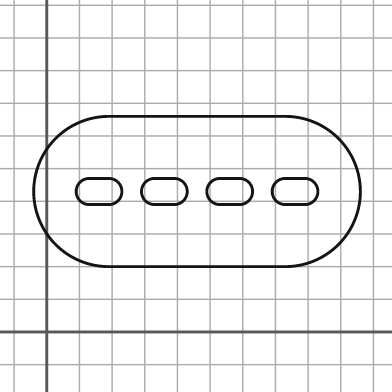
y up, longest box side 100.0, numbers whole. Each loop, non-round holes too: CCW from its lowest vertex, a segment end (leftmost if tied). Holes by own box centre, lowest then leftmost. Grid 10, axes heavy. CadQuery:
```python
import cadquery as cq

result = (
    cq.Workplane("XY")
    .moveTo(19.0, 20.0)
    .lineTo(73.0, 20.0)
    .threePointArc((96.0, 43.0), (73.0, 66.0))
    .lineTo(19.0, 66.0)
    .threePointArc((-4.0, 43.0), (19.0, 20.0))
    .close()
    .moveTo(13.0, 39.0)
    .lineTo(19.0, 39.0)
    .threePointArc((23.0, 43.0), (19.0, 47.0))
    .lineTo(13.0, 47.0)
    .threePointArc((9.0, 43.0), (13.0, 39.0))
    .close()
    .moveTo(33.0, 39.0)
    .lineTo(39.0, 39.0)
    .threePointArc((43.0, 43.0), (39.0, 47.0))
    .lineTo(33.0, 47.0)
    .threePointArc((29.0, 43.0), (33.0, 39.0))
    .close()
    .moveTo(53.0, 39.0)
    .lineTo(59.0, 39.0)
    .threePointArc((63.0, 43.0), (59.0, 47.0))
    .lineTo(53.0, 47.0)
    .threePointArc((49.0, 43.0), (53.0, 39.0))
    .close()
    .moveTo(73.0, 39.0)
    .lineTo(79.0, 39.0)
    .threePointArc((83.0, 43.0), (79.0, 47.0))
    .lineTo(73.0, 47.0)
    .threePointArc((69.0, 43.0), (73.0, 39.0))
    .close()
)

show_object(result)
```